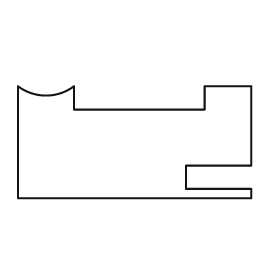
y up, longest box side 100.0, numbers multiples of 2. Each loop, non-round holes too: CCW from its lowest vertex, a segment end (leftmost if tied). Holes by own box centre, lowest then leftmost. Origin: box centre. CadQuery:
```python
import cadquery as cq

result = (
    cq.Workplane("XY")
    .moveTo(-50.0, -24.0)
    .lineTo(50.0, -24.0)
    .lineTo(50.0, -20.0)
    .lineTo(22.0, -20.0)
    .lineTo(22.0, -10.0)
    .lineTo(50.0, -10.0)
    .lineTo(50.0, 24.0)
    .lineTo(30.0, 24.0)
    .lineTo(30.0, 14.0)
    .lineTo(-26.0, 14.0)
    .lineTo(-26.0, 24.0)
    .threePointArc((-38.0, 20.0), (-50.0, 24.0))
    .close()
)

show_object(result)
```